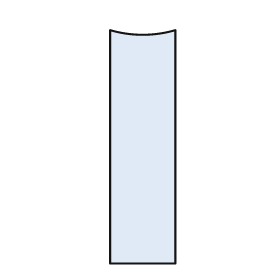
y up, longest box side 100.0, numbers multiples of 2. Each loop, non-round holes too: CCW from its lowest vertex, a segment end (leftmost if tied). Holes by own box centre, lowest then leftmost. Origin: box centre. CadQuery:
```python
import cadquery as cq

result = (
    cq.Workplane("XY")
    .moveTo(-14.0, -50.0)
    .lineTo(14.0, -50.0)
    .lineTo(14.0, 50.0)
    .threePointArc((0.0, 48.0), (-14.0, 50.0))
    .close()
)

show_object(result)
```